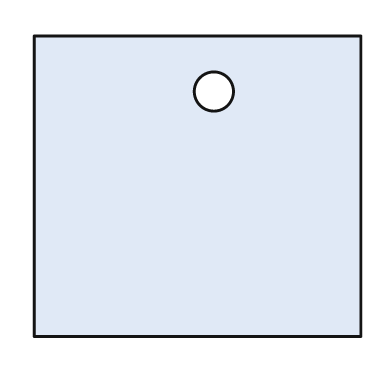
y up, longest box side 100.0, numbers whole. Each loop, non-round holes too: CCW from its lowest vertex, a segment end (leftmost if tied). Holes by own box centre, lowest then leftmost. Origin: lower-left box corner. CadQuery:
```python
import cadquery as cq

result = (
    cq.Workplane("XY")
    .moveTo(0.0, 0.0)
    .lineTo(100.0, 0.0)
    .lineTo(100.0, 92.0)
    .lineTo(0.0, 92.0)
    .close()
    .moveTo(55.0, 75.0)
    .circle(6.0)
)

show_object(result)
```